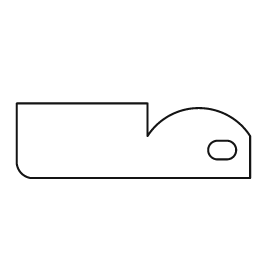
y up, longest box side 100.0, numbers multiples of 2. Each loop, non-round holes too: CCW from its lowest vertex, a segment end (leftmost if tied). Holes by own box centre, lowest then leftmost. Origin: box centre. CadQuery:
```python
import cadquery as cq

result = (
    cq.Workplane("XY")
    .moveTo(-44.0, -16.0)
    .lineTo(50.0, -16.0)
    .lineTo(50.0, 2.0)
    .threePointArc((28.0, 14.0), (6.0, 2.0))
    .lineTo(6.0, 16.0)
    .lineTo(-50.0, 16.0)
    .lineTo(-50.0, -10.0)
    .threePointArc((-48.0, -14.0), (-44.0, -16.0))
    .close()
    .moveTo(36.0, -8.0)
    .lineTo(40.0, -8.0)
    .threePointArc((44.0, -4.0), (40.0, 0.0))
    .lineTo(36.0, 0.0)
    .threePointArc((32.0, -4.0), (36.0, -8.0))
    .close()
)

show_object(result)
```